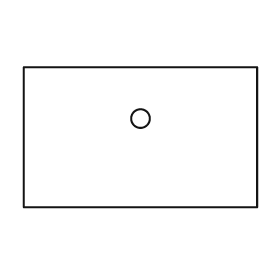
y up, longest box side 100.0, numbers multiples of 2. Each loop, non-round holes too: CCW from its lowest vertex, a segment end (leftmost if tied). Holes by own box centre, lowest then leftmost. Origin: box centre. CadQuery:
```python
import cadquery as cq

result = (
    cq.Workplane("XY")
    .moveTo(-50.0, -30.0)
    .lineTo(50.0, -30.0)
    .lineTo(50.0, 30.0)
    .lineTo(-50.0, 30.0)
    .close()
    .moveTo(0.0, 8.0)
    .circle(4.0)
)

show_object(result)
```